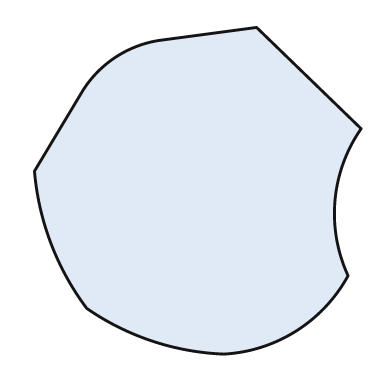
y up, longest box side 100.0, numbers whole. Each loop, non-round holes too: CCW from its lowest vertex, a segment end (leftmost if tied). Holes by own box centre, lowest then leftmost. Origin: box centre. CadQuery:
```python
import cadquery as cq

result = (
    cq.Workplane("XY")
    .moveTo(8.0, -50.0)
    .threePointArc((30.0, -43.0), (46.0, -26.0))
    .threePointArc((42.0, -3.0), (50.0, 19.0))
    .lineTo(18.0, 50.0)
    .lineTo(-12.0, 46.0)
    .threePointArc((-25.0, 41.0), (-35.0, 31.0))
    .lineTo(-50.0, 6.0)
    .threePointArc((-45.0, -16.0), (-34.0, -36.0))
    .threePointArc((-14.0, -46.0), (8.0, -50.0))
    .close()
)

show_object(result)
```